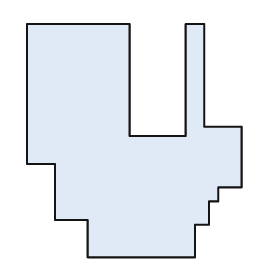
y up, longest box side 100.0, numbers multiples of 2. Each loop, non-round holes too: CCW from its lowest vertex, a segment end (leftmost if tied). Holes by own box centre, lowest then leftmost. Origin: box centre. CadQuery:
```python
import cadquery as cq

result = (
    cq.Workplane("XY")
    .moveTo(-20.0, -50.0)
    .lineTo(26.0, -50.0)
    .lineTo(26.0, -36.0)
    .lineTo(32.0, -36.0)
    .lineTo(32.0, -26.0)
    .lineTo(36.0, -26.0)
    .lineTo(36.0, -20.0)
    .lineTo(46.0, -20.0)
    .lineTo(46.0, 6.0)
    .lineTo(30.0, 6.0)
    .lineTo(30.0, 50.0)
    .lineTo(22.0, 50.0)
    .lineTo(22.0, 2.0)
    .lineTo(-2.0, 2.0)
    .lineTo(-2.0, 50.0)
    .lineTo(-46.0, 50.0)
    .lineTo(-46.0, -10.0)
    .lineTo(-34.0, -10.0)
    .lineTo(-34.0, -34.0)
    .lineTo(-20.0, -34.0)
    .close()
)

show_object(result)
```